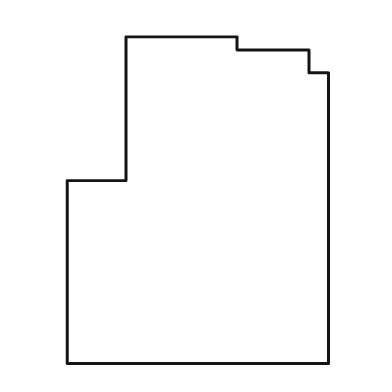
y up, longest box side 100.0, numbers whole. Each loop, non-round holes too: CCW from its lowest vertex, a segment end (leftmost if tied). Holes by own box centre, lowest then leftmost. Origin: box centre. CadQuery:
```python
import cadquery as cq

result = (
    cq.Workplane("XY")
    .moveTo(-40.0, -50.0)
    .lineTo(40.0, -50.0)
    .lineTo(40.0, 39.0)
    .lineTo(34.0, 39.0)
    .lineTo(34.0, 46.0)
    .lineTo(12.0, 46.0)
    .lineTo(12.0, 50.0)
    .lineTo(-22.0, 50.0)
    .lineTo(-22.0, 6.0)
    .lineTo(-40.0, 6.0)
    .close()
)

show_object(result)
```